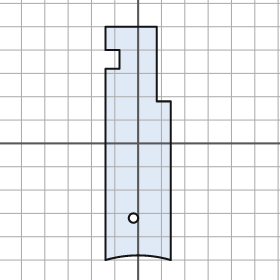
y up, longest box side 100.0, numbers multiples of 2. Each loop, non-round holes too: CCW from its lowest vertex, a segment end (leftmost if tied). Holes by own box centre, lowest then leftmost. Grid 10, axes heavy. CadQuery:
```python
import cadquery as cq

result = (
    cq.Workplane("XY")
    .moveTo(-14.0, -50.0)
    .threePointArc((0.0, -48.0), (14.0, -50.0))
    .lineTo(14.0, 18.0)
    .lineTo(8.0, 18.0)
    .lineTo(8.0, 50.0)
    .lineTo(-14.0, 50.0)
    .lineTo(-14.0, 40.0)
    .lineTo(-8.0, 40.0)
    .lineTo(-8.0, 32.0)
    .lineTo(-14.0, 32.0)
    .close()
    .moveTo(-2.0, -32.0)
    .circle(2.0)
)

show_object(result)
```